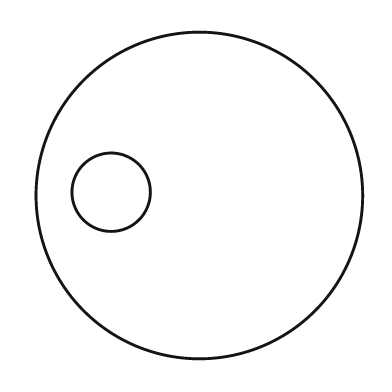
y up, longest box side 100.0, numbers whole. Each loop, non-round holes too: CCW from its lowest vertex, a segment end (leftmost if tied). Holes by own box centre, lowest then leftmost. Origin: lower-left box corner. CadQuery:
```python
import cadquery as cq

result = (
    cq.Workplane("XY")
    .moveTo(50.0, 50.0)
    .circle(50.0)
    .moveTo(23.0, 51.0)
    .circle(12.0)
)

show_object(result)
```